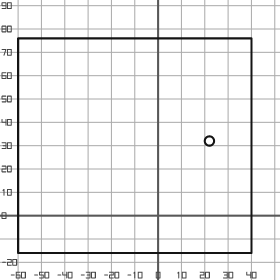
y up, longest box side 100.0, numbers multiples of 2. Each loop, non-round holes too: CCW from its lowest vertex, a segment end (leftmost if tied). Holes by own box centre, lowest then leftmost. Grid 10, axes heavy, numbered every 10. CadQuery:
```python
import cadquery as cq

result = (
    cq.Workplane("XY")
    .moveTo(-60.0, -16.0)
    .lineTo(40.0, -16.0)
    .lineTo(40.0, 76.0)
    .lineTo(-60.0, 76.0)
    .close()
    .moveTo(22.0, 32.0)
    .circle(2.0)
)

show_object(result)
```